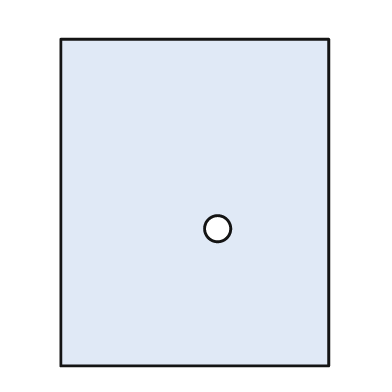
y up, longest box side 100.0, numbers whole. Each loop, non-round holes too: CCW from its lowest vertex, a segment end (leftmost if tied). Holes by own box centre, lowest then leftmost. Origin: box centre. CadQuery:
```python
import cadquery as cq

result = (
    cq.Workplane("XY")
    .moveTo(-41.0, -50.0)
    .lineTo(41.0, -50.0)
    .lineTo(41.0, 50.0)
    .lineTo(-41.0, 50.0)
    .close()
    .moveTo(7.0, -8.0)
    .circle(4.0)
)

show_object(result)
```